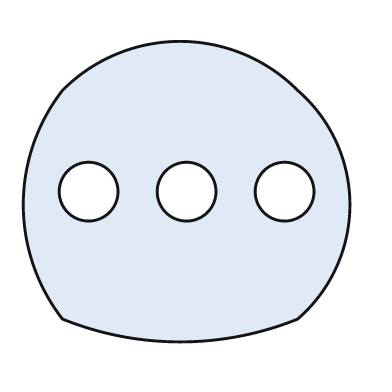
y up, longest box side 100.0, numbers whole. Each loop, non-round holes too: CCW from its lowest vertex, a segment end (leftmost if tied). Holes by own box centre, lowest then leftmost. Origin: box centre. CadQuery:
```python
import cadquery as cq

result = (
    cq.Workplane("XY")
    .moveTo(-38.0, -39.0)
    .threePointArc((-2.0, -46.0), (34.0, -39.0))
    .threePointArc((50.0, -4.0), (34.0, 31.0))
    .threePointArc((-2.0, 46.0), (-38.0, 31.0))
    .threePointArc((-50.0, -4.0), (-38.0, -39.0))
    .close()
    .moveTo(-30.0, 0.0)
    .circle(9.0)
    .moveTo(0.0, 0.0)
    .circle(9.0)
    .moveTo(30.0, 0.0)
    .circle(9.0)
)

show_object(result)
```